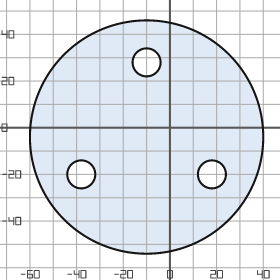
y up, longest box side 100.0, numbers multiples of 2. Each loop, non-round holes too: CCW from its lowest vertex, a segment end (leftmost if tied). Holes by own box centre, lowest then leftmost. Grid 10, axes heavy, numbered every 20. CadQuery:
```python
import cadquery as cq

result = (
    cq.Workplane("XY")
    .moveTo(-10.0, -4.0)
    .circle(50.0)
    .moveTo(-38.0, -20.0)
    .circle(6.0)
    .moveTo(18.0, -20.0)
    .circle(6.0)
    .moveTo(-10.0, 28.0)
    .circle(6.0)
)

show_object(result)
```